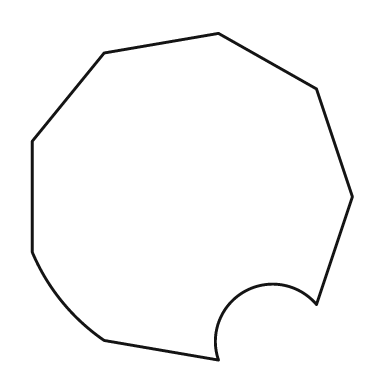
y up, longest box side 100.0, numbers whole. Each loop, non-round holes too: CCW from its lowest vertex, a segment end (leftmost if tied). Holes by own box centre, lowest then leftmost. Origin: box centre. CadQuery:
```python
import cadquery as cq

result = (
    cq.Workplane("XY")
    .moveTo(8.0, -50.0)
    .threePointArc((16.0, -29.0), (38.0, -33.0))
    .lineTo(49.0, 0.0)
    .lineTo(38.0, 33.0)
    .lineTo(8.0, 50.0)
    .lineTo(-27.0, 44.0)
    .lineTo(-49.0, 17.0)
    .lineTo(-49.0, -17.0)
    .threePointArc((-40.0, -32.0), (-27.0, -44.0))
    .close()
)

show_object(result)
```